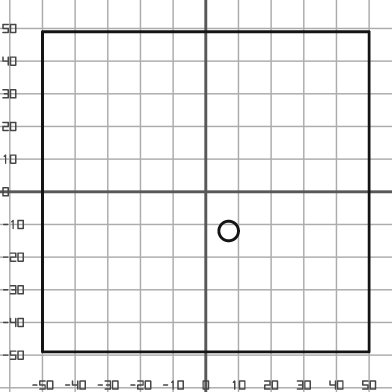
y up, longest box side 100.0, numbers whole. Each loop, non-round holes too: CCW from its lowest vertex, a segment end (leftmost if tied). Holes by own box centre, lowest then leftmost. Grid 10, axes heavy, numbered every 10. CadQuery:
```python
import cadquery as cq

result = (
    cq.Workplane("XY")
    .moveTo(-50.0, -49.0)
    .lineTo(50.0, -49.0)
    .lineTo(50.0, 49.0)
    .lineTo(-50.0, 49.0)
    .close()
    .moveTo(7.0, -12.0)
    .circle(3.0)
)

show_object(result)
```